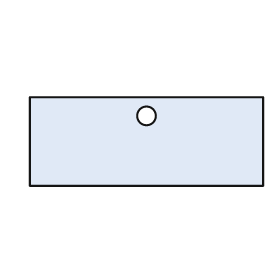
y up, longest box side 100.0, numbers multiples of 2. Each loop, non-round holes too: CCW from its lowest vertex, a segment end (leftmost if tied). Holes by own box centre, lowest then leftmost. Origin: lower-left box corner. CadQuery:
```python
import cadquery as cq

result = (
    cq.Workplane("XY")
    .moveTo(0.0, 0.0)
    .lineTo(100.0, 0.0)
    .lineTo(100.0, 38.0)
    .lineTo(0.0, 38.0)
    .close()
    .moveTo(50.0, 30.0)
    .circle(4.0)
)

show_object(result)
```